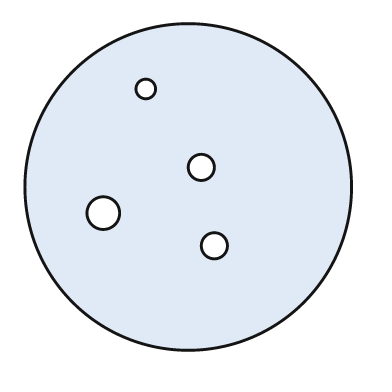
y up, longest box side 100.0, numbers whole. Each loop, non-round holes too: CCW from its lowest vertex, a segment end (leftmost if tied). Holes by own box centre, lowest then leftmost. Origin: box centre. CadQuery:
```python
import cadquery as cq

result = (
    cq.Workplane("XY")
    .moveTo(0.0, 0.0)
    .circle(50.0)
    .moveTo(8.0, -18.0)
    .circle(4.0)
    .moveTo(-26.0, -8.0)
    .circle(5.0)
    .moveTo(4.0, 6.0)
    .circle(4.0)
    .moveTo(-13.0, 30.0)
    .circle(3.0)
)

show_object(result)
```